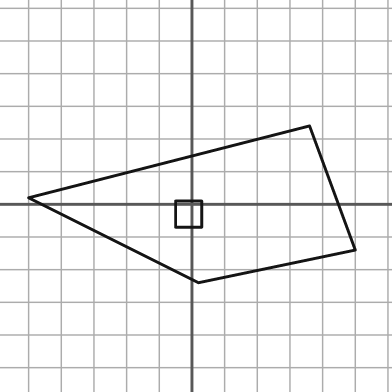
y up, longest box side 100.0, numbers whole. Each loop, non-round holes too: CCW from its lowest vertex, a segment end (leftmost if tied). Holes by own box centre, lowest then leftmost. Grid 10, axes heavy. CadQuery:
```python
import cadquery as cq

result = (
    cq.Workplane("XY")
    .moveTo(2.0, -24.0)
    .lineTo(50.0, -14.0)
    .lineTo(36.0, 24.0)
    .lineTo(-50.0, 2.0)
    .close()
    .moveTo(-5.0, -7.0)
    .lineTo(3.0, -7.0)
    .lineTo(3.0, 1.0)
    .lineTo(-5.0, 1.0)
    .close()
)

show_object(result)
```